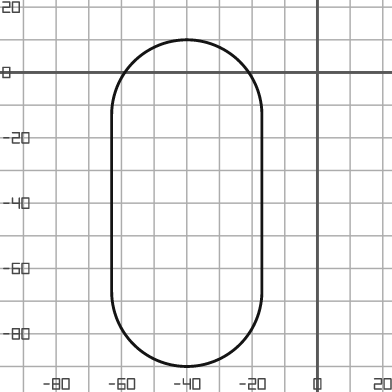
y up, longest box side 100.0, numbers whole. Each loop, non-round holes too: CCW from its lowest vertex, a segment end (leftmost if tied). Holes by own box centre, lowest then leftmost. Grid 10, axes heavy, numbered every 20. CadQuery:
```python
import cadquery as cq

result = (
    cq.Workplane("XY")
    .moveTo(-63.0, -67.0)
    .threePointArc((-40.0, -90.0), (-17.0, -67.0))
    .lineTo(-17.0, -13.0)
    .threePointArc((-40.0, 10.0), (-63.0, -13.0))
    .close()
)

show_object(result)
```